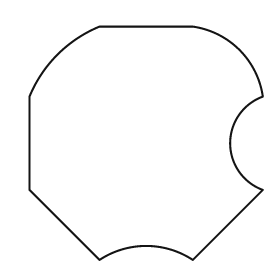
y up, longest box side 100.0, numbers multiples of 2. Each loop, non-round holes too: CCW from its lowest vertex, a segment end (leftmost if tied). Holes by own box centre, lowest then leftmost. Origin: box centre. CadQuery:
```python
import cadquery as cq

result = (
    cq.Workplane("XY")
    .moveTo(-20.0, -50.0)
    .threePointArc((0.0, -44.0), (20.0, -50.0))
    .lineTo(50.0, -20.0)
    .threePointArc((36.0, 0.0), (50.0, 20.0))
    .threePointArc((40.0, 40.0), (20.0, 50.0))
    .lineTo(-20.0, 50.0)
    .threePointArc((-38.0, 38.0), (-50.0, 20.0))
    .lineTo(-50.0, -20.0)
    .close()
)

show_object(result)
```